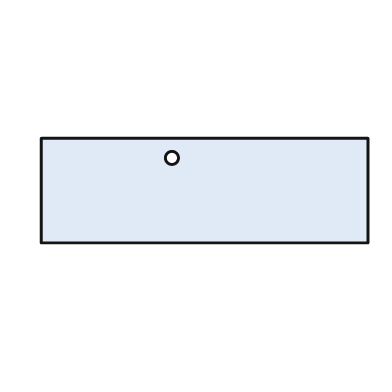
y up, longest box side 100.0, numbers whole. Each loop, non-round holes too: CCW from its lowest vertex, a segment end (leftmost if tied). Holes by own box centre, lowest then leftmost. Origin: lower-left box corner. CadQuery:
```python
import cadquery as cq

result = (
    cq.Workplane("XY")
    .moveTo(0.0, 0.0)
    .lineTo(100.0, 0.0)
    .lineTo(100.0, 32.0)
    .lineTo(0.0, 32.0)
    .close()
    .moveTo(40.0, 26.0)
    .circle(2.0)
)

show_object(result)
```